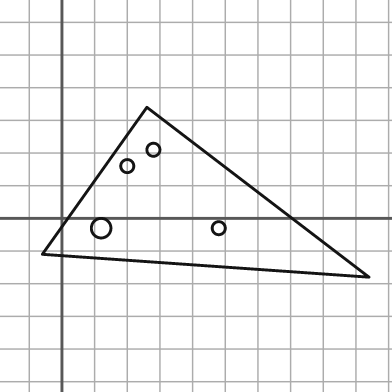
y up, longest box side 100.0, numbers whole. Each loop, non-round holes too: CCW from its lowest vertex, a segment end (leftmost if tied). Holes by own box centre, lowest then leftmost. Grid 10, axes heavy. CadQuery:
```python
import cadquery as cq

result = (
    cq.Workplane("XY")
    .moveTo(94.0, -18.0)
    .lineTo(26.0, 34.0)
    .lineTo(-6.0, -11.0)
    .close()
    .moveTo(12.0, -3.0)
    .circle(3.0)
    .moveTo(48.0, -3.0)
    .circle(2.0)
    .moveTo(20.0, 16.0)
    .circle(2.0)
    .moveTo(28.0, 21.0)
    .circle(2.0)
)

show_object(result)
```